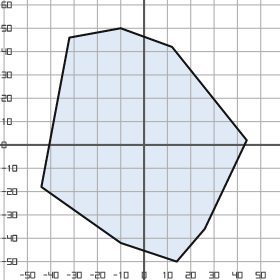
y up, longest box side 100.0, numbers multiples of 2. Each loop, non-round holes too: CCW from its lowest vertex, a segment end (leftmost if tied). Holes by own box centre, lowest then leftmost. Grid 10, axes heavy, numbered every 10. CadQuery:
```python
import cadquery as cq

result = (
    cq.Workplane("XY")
    .moveTo(14.0, -50.0)
    .lineTo(26.0, -36.0)
    .lineTo(44.0, 2.0)
    .lineTo(12.0, 42.0)
    .lineTo(-10.0, 50.0)
    .lineTo(-32.0, 46.0)
    .lineTo(-44.0, -18.0)
    .lineTo(-10.0, -42.0)
    .close()
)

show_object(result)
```